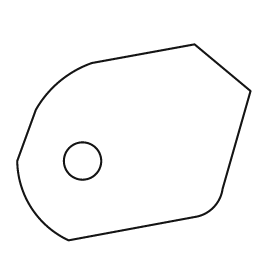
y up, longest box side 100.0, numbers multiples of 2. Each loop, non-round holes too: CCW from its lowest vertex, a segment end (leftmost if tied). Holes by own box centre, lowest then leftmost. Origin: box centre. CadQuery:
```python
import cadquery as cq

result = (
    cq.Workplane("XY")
    .moveTo(-28.0, -42.0)
    .lineTo(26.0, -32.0)
    .threePointArc((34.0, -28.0), (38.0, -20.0))
    .lineTo(50.0, 22.0)
    .lineTo(26.0, 42.0)
    .lineTo(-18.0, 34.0)
    .threePointArc((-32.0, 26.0), (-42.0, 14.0))
    .lineTo(-50.0, -8.0)
    .threePointArc((-44.0, -28.0), (-28.0, -42.0))
    .close()
    .moveTo(-22.0, -8.0)
    .circle(8.0)
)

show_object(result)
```